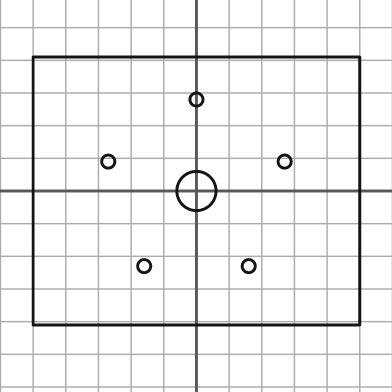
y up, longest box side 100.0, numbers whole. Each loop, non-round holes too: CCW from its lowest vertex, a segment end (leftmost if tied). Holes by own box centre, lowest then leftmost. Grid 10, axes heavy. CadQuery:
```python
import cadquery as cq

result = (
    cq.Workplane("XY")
    .moveTo(-50.0, -41.0)
    .lineTo(50.0, -41.0)
    .lineTo(50.0, 41.0)
    .lineTo(-50.0, 41.0)
    .close()
    .moveTo(-16.0, -23.0)
    .circle(2.0)
    .moveTo(16.0, -23.0)
    .circle(2.0)
    .moveTo(0.0, 0.0)
    .circle(6.0)
    .moveTo(-27.0, 9.0)
    .circle(2.0)
    .moveTo(27.0, 9.0)
    .circle(2.0)
    .moveTo(0.0, 28.0)
    .circle(2.0)
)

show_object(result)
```